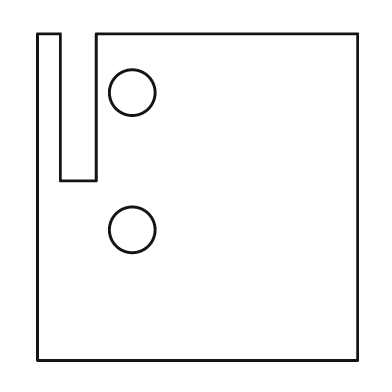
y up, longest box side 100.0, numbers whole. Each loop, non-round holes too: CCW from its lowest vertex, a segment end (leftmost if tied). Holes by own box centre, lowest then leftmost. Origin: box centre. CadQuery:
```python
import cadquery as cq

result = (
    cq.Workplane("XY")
    .moveTo(-49.0, -50.0)
    .lineTo(49.0, -50.0)
    .lineTo(49.0, 50.0)
    .lineTo(-31.0, 50.0)
    .lineTo(-31.0, 5.0)
    .lineTo(-42.0, 5.0)
    .lineTo(-42.0, 50.0)
    .lineTo(-49.0, 50.0)
    .close()
    .moveTo(-20.0, -10.0)
    .circle(7.0)
    .moveTo(-20.0, 32.0)
    .circle(7.0)
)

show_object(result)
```